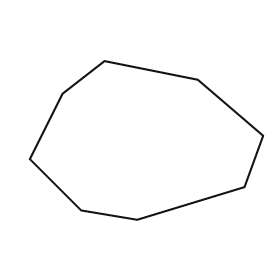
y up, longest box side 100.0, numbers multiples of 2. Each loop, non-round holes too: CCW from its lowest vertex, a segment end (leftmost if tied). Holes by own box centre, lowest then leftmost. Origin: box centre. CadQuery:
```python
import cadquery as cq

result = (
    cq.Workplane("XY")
    .moveTo(-4.0, -34.0)
    .lineTo(42.0, -20.0)
    .lineTo(50.0, 2.0)
    .lineTo(22.0, 26.0)
    .lineTo(-18.0, 34.0)
    .lineTo(-36.0, 20.0)
    .lineTo(-50.0, -8.0)
    .lineTo(-28.0, -30.0)
    .close()
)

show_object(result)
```